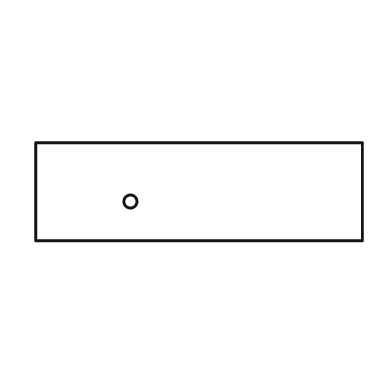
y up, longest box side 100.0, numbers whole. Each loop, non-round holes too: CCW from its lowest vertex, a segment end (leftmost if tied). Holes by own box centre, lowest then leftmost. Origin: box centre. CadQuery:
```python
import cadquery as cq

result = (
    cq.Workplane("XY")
    .moveTo(-50.0, -15.0)
    .lineTo(50.0, -15.0)
    .lineTo(50.0, 15.0)
    .lineTo(-50.0, 15.0)
    .close()
    .moveTo(-21.0, -3.0)
    .circle(2.0)
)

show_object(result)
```